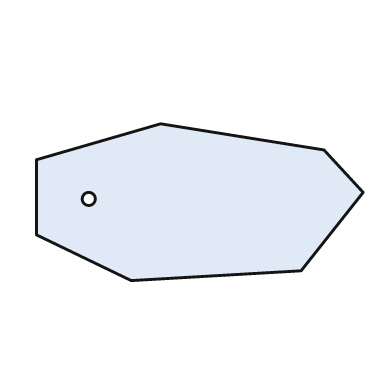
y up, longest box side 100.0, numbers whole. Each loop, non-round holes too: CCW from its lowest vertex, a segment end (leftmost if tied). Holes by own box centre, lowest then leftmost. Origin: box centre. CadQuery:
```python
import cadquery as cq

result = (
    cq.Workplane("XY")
    .moveTo(-21.0, -24.0)
    .lineTo(31.0, -21.0)
    .lineTo(50.0, 3.0)
    .lineTo(38.0, 16.0)
    .lineTo(-12.0, 24.0)
    .lineTo(-50.0, 13.0)
    .lineTo(-50.0, -10.0)
    .close()
    .moveTo(-34.0, 1.0)
    .circle(2.0)
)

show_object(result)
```